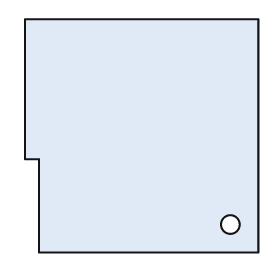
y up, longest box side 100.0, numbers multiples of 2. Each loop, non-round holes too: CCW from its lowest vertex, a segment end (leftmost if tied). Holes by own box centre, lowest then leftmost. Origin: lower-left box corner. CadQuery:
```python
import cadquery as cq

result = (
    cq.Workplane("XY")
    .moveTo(6.0, 0.0)
    .lineTo(100.0, 0.0)
    .lineTo(100.0, 100.0)
    .lineTo(0.0, 100.0)
    .lineTo(0.0, 40.0)
    .lineTo(6.0, 40.0)
    .close()
    .moveTo(88.0, 12.0)
    .circle(4.0)
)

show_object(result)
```